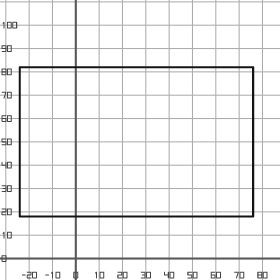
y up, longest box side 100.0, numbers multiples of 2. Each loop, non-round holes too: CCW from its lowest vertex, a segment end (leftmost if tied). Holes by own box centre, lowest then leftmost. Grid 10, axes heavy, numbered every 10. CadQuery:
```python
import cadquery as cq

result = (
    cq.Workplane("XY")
    .moveTo(-24.0, 18.0)
    .lineTo(76.0, 18.0)
    .lineTo(76.0, 82.0)
    .lineTo(-24.0, 82.0)
    .close()
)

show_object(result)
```